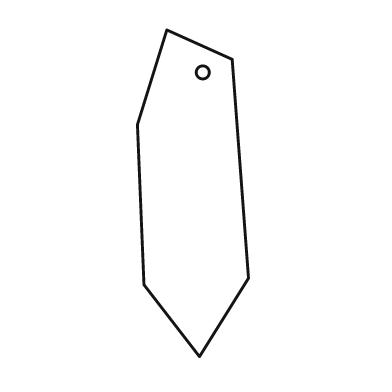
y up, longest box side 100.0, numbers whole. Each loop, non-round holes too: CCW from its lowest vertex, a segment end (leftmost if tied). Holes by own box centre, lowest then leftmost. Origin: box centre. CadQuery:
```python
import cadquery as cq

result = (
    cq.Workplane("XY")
    .moveTo(2.0, -50.0)
    .lineTo(17.0, -26.0)
    .lineTo(12.0, 41.0)
    .lineTo(-8.0, 50.0)
    .lineTo(-17.0, 21.0)
    .lineTo(-15.0, -28.0)
    .close()
    .moveTo(3.0, 37.0)
    .circle(2.0)
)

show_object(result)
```